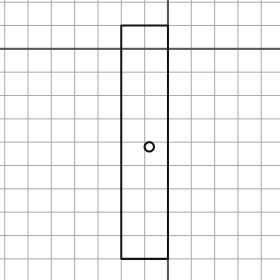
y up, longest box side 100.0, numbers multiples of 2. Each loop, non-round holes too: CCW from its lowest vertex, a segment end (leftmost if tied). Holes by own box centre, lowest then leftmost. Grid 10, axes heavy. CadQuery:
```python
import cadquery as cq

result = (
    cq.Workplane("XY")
    .moveTo(-20.0, -90.0)
    .lineTo(0.0, -90.0)
    .lineTo(0.0, 10.0)
    .lineTo(-20.0, 10.0)
    .close()
    .moveTo(-8.0, -42.0)
    .circle(2.0)
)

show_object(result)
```